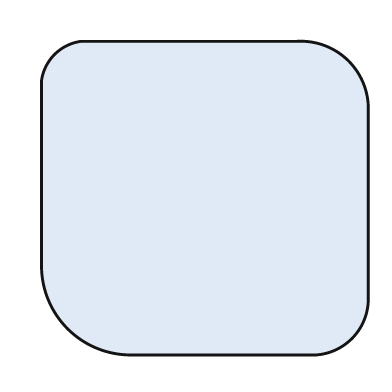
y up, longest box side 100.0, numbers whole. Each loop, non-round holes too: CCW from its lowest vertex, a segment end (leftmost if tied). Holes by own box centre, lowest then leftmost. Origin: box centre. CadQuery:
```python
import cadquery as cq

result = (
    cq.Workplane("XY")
    .moveTo(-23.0, -48.0)
    .lineTo(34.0, -48.0)
    .threePointArc((45.0, -43.0), (50.0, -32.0))
    .lineTo(50.0, 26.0)
    .threePointArc((44.0, 42.0), (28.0, 48.0))
    .lineTo(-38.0, 48.0)
    .threePointArc((-46.0, 44.0), (-50.0, 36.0))
    .lineTo(-50.0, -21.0)
    .threePointArc((-42.0, -40.0), (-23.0, -48.0))
    .close()
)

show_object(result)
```